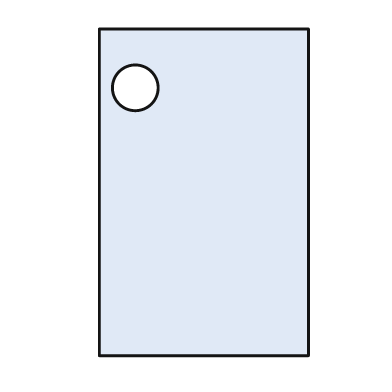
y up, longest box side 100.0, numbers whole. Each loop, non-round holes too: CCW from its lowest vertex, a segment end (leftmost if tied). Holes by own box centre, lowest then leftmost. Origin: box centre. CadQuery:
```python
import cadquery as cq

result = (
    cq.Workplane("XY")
    .moveTo(-32.0, -50.0)
    .lineTo(32.0, -50.0)
    .lineTo(32.0, 50.0)
    .lineTo(-32.0, 50.0)
    .close()
    .moveTo(-21.0, 32.0)
    .circle(7.0)
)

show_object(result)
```